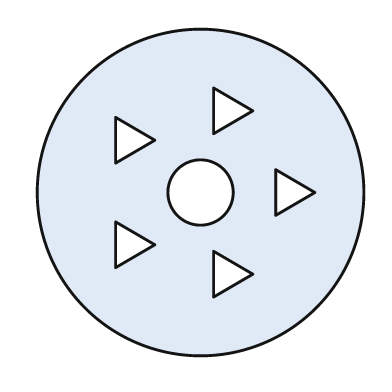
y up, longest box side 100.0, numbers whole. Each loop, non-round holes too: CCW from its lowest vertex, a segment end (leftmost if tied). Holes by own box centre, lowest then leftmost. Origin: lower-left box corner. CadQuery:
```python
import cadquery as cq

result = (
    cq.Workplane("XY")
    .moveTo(50.0, 50.0)
    .circle(50.0)
    .moveTo(54.0, 18.0)
    .lineTo(66.0, 25.0)
    .lineTo(54.0, 32.0)
    .close()
    .moveTo(24.0, 27.0)
    .lineTo(36.0, 34.0)
    .lineTo(24.0, 41.0)
    .close()
    .moveTo(50.0, 50.0)
    .circle(10.0)
    .moveTo(73.0, 43.0)
    .lineTo(85.0, 50.0)
    .lineTo(73.0, 57.0)
    .close()
    .moveTo(24.0, 59.0)
    .lineTo(36.0, 66.0)
    .lineTo(24.0, 73.0)
    .close()
    .moveTo(54.0, 68.0)
    .lineTo(66.0, 75.0)
    .lineTo(54.0, 82.0)
    .close()
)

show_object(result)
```